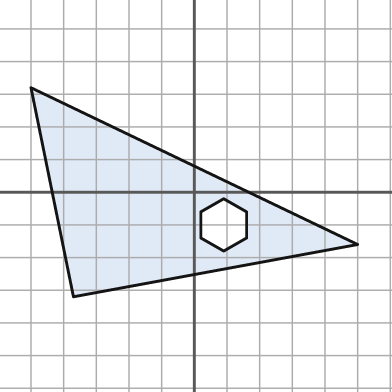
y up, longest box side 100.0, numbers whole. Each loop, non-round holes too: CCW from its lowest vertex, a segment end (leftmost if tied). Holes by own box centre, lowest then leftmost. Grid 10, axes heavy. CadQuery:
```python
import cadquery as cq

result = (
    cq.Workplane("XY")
    .moveTo(-37.0, -32.0)
    .lineTo(50.0, -16.0)
    .lineTo(-50.0, 32.0)
    .close()
    .moveTo(9.0, -18.0)
    .lineTo(16.0, -14.0)
    .lineTo(16.0, -6.0)
    .lineTo(9.0, -2.0)
    .lineTo(2.0, -6.0)
    .lineTo(2.0, -14.0)
    .close()
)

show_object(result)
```